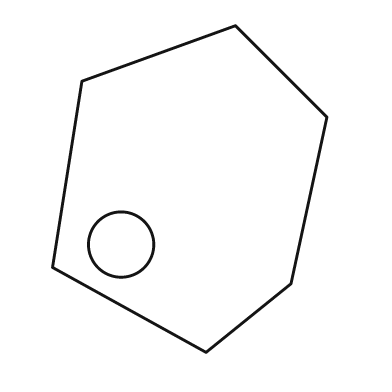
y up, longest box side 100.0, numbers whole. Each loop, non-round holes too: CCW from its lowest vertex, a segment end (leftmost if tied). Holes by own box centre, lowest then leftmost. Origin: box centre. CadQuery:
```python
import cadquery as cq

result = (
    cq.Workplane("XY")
    .moveTo(5.0, -50.0)
    .lineTo(31.0, -29.0)
    .lineTo(42.0, 22.0)
    .lineTo(14.0, 50.0)
    .lineTo(-33.0, 33.0)
    .lineTo(-42.0, -24.0)
    .close()
    .moveTo(-21.0, -17.0)
    .circle(10.0)
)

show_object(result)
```